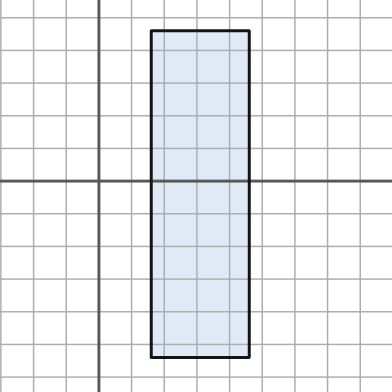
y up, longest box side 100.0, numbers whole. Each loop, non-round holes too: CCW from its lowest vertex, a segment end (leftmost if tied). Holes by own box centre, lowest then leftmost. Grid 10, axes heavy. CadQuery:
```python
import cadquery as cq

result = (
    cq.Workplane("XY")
    .moveTo(16.0, -54.0)
    .lineTo(46.0, -54.0)
    .lineTo(46.0, 46.0)
    .lineTo(16.0, 46.0)
    .close()
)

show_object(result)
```